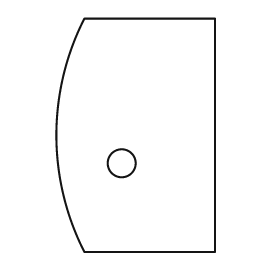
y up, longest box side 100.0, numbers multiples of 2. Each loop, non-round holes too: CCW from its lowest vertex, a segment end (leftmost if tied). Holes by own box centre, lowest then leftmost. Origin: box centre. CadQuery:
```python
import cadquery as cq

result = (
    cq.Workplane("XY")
    .moveTo(-22.0, -50.0)
    .lineTo(34.0, -50.0)
    .lineTo(34.0, 50.0)
    .lineTo(-22.0, 50.0)
    .threePointArc((-34.0, 0.0), (-22.0, -50.0))
    .close()
    .moveTo(-6.0, -12.0)
    .circle(6.0)
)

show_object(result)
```